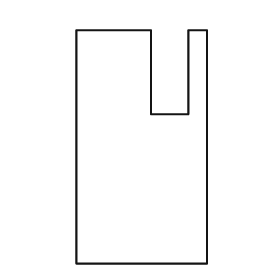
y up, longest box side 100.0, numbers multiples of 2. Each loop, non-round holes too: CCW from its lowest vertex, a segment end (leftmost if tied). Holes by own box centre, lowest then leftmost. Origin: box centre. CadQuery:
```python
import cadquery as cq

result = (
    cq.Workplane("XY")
    .moveTo(-28.0, -50.0)
    .lineTo(28.0, -50.0)
    .lineTo(28.0, 50.0)
    .lineTo(20.0, 50.0)
    .lineTo(20.0, 14.0)
    .lineTo(4.0, 14.0)
    .lineTo(4.0, 50.0)
    .lineTo(-28.0, 50.0)
    .close()
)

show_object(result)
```